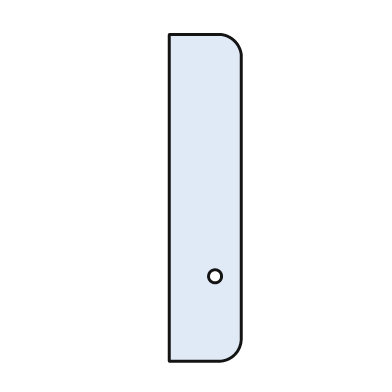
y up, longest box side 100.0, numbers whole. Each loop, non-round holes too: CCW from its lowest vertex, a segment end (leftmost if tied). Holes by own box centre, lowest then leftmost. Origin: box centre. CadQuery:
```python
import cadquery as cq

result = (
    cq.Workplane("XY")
    .moveTo(-11.0, -50.0)
    .lineTo(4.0, -50.0)
    .threePointArc((9.0, -48.0), (11.0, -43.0))
    .lineTo(11.0, 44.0)
    .threePointArc((9.0, 48.0), (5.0, 50.0))
    .lineTo(-11.0, 50.0)
    .close()
    .moveTo(3.0, -24.0)
    .circle(2.0)
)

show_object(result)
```